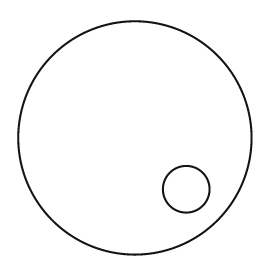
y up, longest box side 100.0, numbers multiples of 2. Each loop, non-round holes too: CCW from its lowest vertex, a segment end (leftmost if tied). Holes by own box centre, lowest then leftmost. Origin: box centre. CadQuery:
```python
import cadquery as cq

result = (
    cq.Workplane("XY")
    .moveTo(0.0, 0.0)
    .circle(50.0)
    .moveTo(22.0, -22.0)
    .circle(10.0)
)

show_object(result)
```